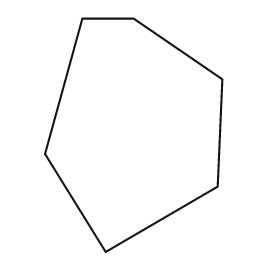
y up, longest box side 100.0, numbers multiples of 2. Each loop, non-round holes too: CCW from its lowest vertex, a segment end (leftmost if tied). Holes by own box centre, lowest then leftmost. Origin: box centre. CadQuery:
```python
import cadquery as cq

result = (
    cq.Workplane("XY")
    .moveTo(-12.0, -50.0)
    .lineTo(36.0, -22.0)
    .lineTo(38.0, 24.0)
    .lineTo(0.0, 50.0)
    .lineTo(-22.0, 50.0)
    .lineTo(-38.0, -8.0)
    .close()
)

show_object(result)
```